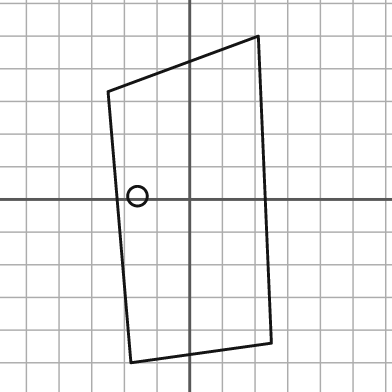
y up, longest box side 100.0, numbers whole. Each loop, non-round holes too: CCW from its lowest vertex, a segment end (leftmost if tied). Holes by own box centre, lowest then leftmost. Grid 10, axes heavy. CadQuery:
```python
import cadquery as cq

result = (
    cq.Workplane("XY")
    .moveTo(-18.0, -50.0)
    .lineTo(25.0, -44.0)
    .lineTo(21.0, 50.0)
    .lineTo(-25.0, 33.0)
    .close()
    .moveTo(-16.0, 1.0)
    .circle(3.0)
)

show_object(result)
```